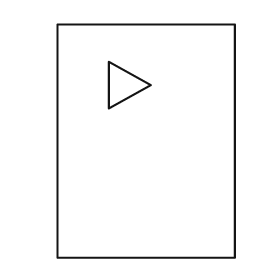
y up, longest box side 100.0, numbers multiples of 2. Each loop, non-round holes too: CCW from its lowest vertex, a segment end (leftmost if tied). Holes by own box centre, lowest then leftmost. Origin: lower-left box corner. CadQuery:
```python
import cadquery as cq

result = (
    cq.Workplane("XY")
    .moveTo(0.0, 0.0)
    .lineTo(76.0, 0.0)
    .lineTo(76.0, 100.0)
    .lineTo(0.0, 100.0)
    .close()
    .moveTo(22.0, 64.0)
    .lineTo(40.0, 74.0)
    .lineTo(22.0, 84.0)
    .close()
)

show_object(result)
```